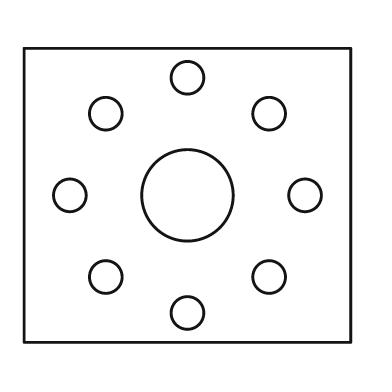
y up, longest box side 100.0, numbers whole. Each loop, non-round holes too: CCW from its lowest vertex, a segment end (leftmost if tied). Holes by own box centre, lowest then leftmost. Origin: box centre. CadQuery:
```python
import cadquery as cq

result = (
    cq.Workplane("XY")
    .moveTo(-50.0, -45.0)
    .lineTo(50.0, -45.0)
    .lineTo(50.0, 45.0)
    .lineTo(-50.0, 45.0)
    .close()
    .moveTo(0.0, -36.0)
    .circle(5.0)
    .moveTo(-25.0, -25.0)
    .circle(5.0)
    .moveTo(25.0, -25.0)
    .circle(5.0)
    .moveTo(-36.0, 0.0)
    .circle(5.0)
    .moveTo(0.0, 0.0)
    .circle(14.0)
    .moveTo(36.0, 0.0)
    .circle(5.0)
    .moveTo(-25.0, 25.0)
    .circle(5.0)
    .moveTo(25.0, 25.0)
    .circle(5.0)
    .moveTo(0.0, 36.0)
    .circle(5.0)
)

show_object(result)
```